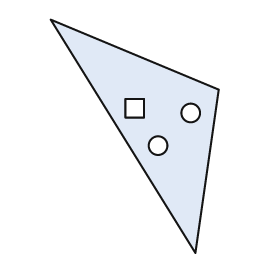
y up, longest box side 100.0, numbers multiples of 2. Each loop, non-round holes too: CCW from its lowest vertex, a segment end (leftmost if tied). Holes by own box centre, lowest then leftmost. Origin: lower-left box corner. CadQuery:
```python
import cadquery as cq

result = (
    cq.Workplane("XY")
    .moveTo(62.0, 0.0)
    .lineTo(72.0, 70.0)
    .lineTo(0.0, 100.0)
    .close()
    .moveTo(46.0, 46.0)
    .circle(4.0)
    .moveTo(60.0, 60.0)
    .circle(4.0)
    .moveTo(32.0, 58.0)
    .lineTo(40.0, 58.0)
    .lineTo(40.0, 66.0)
    .lineTo(32.0, 66.0)
    .close()
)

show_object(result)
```